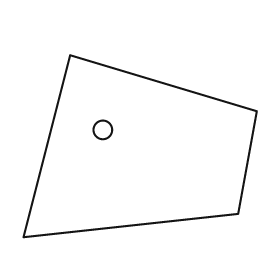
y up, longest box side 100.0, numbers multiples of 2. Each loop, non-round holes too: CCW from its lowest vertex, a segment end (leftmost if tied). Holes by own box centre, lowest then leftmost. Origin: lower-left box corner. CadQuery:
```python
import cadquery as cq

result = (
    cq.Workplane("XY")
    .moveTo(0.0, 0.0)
    .lineTo(92.0, 10.0)
    .lineTo(100.0, 54.0)
    .lineTo(20.0, 78.0)
    .close()
    .moveTo(34.0, 46.0)
    .circle(4.0)
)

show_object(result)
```